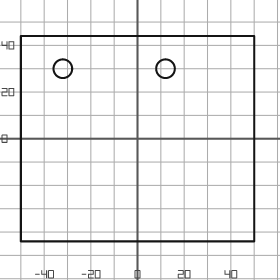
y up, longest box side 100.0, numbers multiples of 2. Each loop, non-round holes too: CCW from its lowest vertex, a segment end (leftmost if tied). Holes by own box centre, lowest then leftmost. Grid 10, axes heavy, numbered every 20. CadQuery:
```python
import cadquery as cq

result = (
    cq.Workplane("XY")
    .moveTo(-50.0, -44.0)
    .lineTo(50.0, -44.0)
    .lineTo(50.0, 44.0)
    .lineTo(-50.0, 44.0)
    .close()
    .moveTo(-32.0, 30.0)
    .circle(4.0)
    .moveTo(12.0, 30.0)
    .circle(4.0)
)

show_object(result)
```